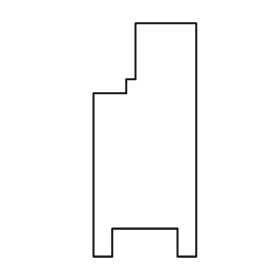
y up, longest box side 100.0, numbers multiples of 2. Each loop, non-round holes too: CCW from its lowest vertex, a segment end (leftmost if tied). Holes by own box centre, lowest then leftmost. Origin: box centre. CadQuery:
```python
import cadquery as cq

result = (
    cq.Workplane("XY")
    .moveTo(-22.0, -50.0)
    .lineTo(-14.0, -50.0)
    .lineTo(-14.0, -38.0)
    .lineTo(14.0, -38.0)
    .lineTo(14.0, -50.0)
    .lineTo(22.0, -50.0)
    .lineTo(22.0, 50.0)
    .lineTo(-4.0, 50.0)
    .lineTo(-4.0, 26.0)
    .lineTo(-8.0, 26.0)
    .lineTo(-8.0, 20.0)
    .lineTo(-22.0, 20.0)
    .close()
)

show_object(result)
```